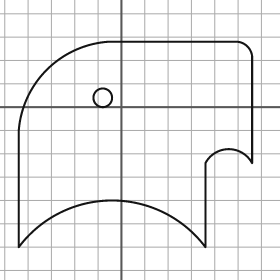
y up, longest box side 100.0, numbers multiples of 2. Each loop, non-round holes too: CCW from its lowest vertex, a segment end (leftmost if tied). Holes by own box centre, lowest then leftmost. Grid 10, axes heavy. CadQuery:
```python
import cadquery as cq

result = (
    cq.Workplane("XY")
    .moveTo(-44.0, -60.0)
    .threePointArc((-4.0, -40.0), (36.0, -60.0))
    .lineTo(36.0, -24.0)
    .threePointArc((46.0, -18.0), (56.0, -24.0))
    .lineTo(56.0, 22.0)
    .threePointArc((54.0, 26.0), (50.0, 28.0))
    .lineTo(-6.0, 28.0)
    .threePointArc((-32.0, 16.0), (-44.0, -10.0))
    .close()
    .moveTo(-8.0, 4.0)
    .circle(4.0)
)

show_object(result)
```